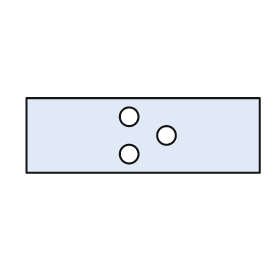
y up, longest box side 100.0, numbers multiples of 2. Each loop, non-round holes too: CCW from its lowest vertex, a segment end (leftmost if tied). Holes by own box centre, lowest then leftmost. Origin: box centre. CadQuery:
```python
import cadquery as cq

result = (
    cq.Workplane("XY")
    .moveTo(-50.0, -16.0)
    .lineTo(50.0, -16.0)
    .lineTo(50.0, 16.0)
    .lineTo(-50.0, 16.0)
    .close()
    .moveTo(-6.0, -8.0)
    .circle(4.0)
    .moveTo(10.0, 0.0)
    .circle(4.0)
    .moveTo(-6.0, 8.0)
    .circle(4.0)
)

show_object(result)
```